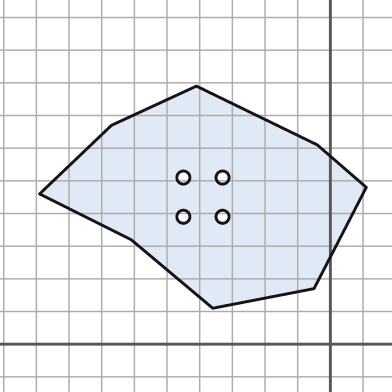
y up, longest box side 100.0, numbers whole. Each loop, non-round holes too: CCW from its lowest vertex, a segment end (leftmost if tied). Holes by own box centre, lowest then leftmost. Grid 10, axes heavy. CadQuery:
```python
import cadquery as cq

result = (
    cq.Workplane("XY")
    .moveTo(-36.0, 11.0)
    .lineTo(-5.0, 17.0)
    .lineTo(11.0, 48.0)
    .lineTo(-4.0, 61.0)
    .lineTo(-41.0, 79.0)
    .lineTo(-67.0, 67.0)
    .lineTo(-89.0, 46.0)
    .lineTo(-61.0, 32.0)
    .close()
    .moveTo(-45.0, 39.0)
    .circle(2.0)
    .moveTo(-33.0, 39.0)
    .circle(2.0)
    .moveTo(-45.0, 51.0)
    .circle(2.0)
    .moveTo(-33.0, 51.0)
    .circle(2.0)
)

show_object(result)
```